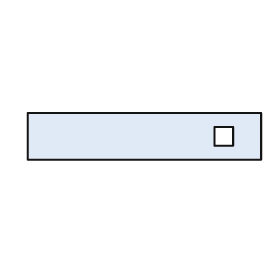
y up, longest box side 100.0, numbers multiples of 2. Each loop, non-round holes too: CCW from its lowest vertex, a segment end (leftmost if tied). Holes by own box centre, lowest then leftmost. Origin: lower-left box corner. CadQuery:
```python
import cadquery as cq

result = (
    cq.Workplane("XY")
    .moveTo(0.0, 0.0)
    .lineTo(100.0, 0.0)
    .lineTo(100.0, 20.0)
    .lineTo(0.0, 20.0)
    .close()
    .moveTo(80.0, 6.0)
    .lineTo(88.0, 6.0)
    .lineTo(88.0, 14.0)
    .lineTo(80.0, 14.0)
    .close()
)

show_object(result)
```